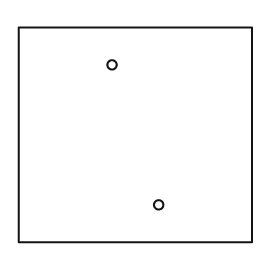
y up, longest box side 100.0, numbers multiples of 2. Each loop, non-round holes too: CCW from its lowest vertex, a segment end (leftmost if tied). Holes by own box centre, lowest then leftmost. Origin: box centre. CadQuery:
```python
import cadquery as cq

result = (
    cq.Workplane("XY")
    .moveTo(-50.0, -46.0)
    .lineTo(50.0, -46.0)
    .lineTo(50.0, 46.0)
    .lineTo(-50.0, 46.0)
    .close()
    .moveTo(10.0, -30.0)
    .circle(2.0)
    .moveTo(-10.0, 30.0)
    .circle(2.0)
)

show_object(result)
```